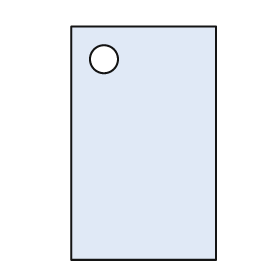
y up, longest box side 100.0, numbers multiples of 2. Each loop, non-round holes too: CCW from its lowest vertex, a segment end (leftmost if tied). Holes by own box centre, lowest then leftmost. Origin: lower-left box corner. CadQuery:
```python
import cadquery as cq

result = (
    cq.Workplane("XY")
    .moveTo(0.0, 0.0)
    .lineTo(62.0, 0.0)
    .lineTo(62.0, 100.0)
    .lineTo(0.0, 100.0)
    .close()
    .moveTo(14.0, 86.0)
    .circle(6.0)
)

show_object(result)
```